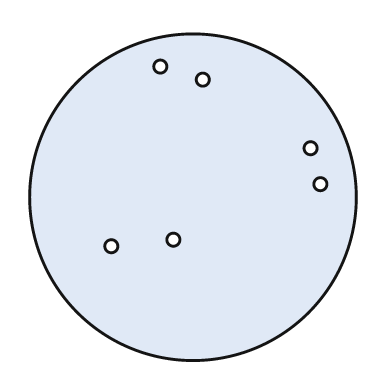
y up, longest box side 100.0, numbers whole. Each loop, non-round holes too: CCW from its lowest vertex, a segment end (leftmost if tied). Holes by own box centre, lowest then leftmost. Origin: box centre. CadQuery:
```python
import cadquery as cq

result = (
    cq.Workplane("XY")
    .moveTo(0.0, 0.0)
    .circle(50.0)
    .moveTo(-25.0, -15.0)
    .circle(2.0)
    .moveTo(-6.0, -13.0)
    .circle(2.0)
    .moveTo(39.0, 4.0)
    .circle(2.0)
    .moveTo(36.0, 15.0)
    .circle(2.0)
    .moveTo(3.0, 36.0)
    .circle(2.0)
    .moveTo(-10.0, 40.0)
    .circle(2.0)
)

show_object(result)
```